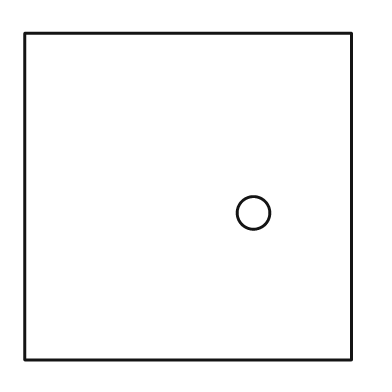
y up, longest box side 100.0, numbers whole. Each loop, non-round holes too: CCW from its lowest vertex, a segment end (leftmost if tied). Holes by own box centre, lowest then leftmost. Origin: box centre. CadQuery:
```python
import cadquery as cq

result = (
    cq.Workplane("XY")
    .moveTo(-50.0, -50.0)
    .lineTo(50.0, -50.0)
    .lineTo(50.0, 50.0)
    .lineTo(-50.0, 50.0)
    .close()
    .moveTo(20.0, -5.0)
    .circle(5.0)
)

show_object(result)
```